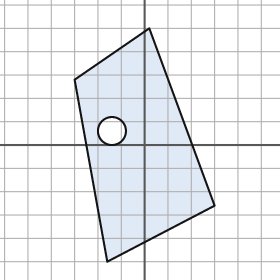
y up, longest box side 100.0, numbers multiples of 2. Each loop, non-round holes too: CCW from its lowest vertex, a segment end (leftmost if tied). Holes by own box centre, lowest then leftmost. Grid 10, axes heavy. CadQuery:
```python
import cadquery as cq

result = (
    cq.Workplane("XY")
    .moveTo(-16.0, -50.0)
    .lineTo(30.0, -26.0)
    .lineTo(2.0, 50.0)
    .lineTo(-30.0, 28.0)
    .close()
    .moveTo(-14.0, 6.0)
    .circle(6.0)
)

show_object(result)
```